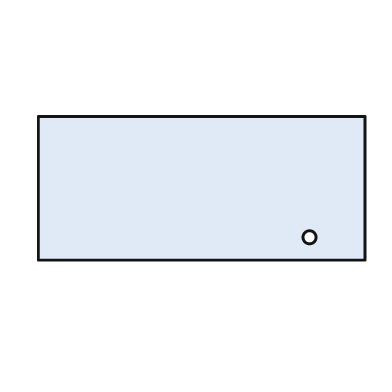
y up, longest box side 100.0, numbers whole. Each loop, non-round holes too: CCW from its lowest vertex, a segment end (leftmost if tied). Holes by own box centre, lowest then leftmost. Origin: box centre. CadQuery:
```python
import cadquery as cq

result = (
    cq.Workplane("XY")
    .moveTo(-50.0, -22.0)
    .lineTo(50.0, -22.0)
    .lineTo(50.0, 22.0)
    .lineTo(-50.0, 22.0)
    .close()
    .moveTo(33.0, -15.0)
    .circle(2.0)
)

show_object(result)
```